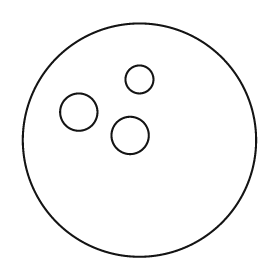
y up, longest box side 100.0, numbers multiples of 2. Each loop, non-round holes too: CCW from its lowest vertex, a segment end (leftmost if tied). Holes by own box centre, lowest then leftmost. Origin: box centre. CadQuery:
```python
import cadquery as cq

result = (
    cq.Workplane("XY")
    .moveTo(0.0, 0.0)
    .circle(50.0)
    .moveTo(-4.0, 2.0)
    .circle(8.0)
    .moveTo(-26.0, 12.0)
    .circle(8.0)
    .moveTo(0.0, 26.0)
    .circle(6.0)
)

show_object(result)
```